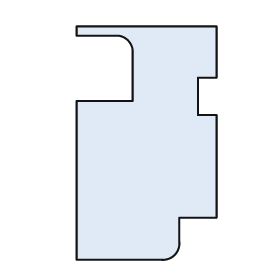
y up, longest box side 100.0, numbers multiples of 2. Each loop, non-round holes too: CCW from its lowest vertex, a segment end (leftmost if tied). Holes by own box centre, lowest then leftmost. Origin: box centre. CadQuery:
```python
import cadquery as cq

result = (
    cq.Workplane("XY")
    .moveTo(-30.0, -50.0)
    .lineTo(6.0, -50.0)
    .threePointArc((12.0, -48.0), (14.0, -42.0))
    .lineTo(14.0, -32.0)
    .lineTo(30.0, -32.0)
    .lineTo(30.0, 12.0)
    .lineTo(22.0, 12.0)
    .lineTo(22.0, 28.0)
    .lineTo(30.0, 28.0)
    .lineTo(30.0, 50.0)
    .lineTo(-30.0, 50.0)
    .lineTo(-30.0, 46.0)
    .lineTo(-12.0, 46.0)
    .threePointArc((-8.0, 44.0), (-6.0, 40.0))
    .lineTo(-6.0, 18.0)
    .lineTo(-30.0, 18.0)
    .close()
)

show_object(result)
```